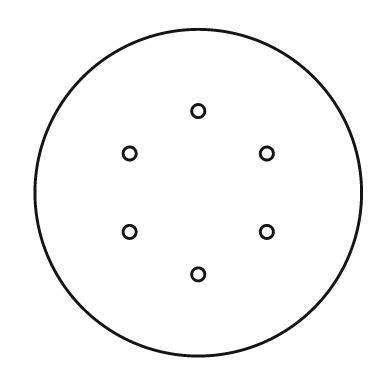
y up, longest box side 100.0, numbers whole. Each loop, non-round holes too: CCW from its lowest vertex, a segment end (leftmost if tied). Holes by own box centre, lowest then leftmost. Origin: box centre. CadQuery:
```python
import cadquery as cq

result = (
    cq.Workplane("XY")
    .moveTo(0.0, 0.0)
    .circle(50.0)
    .moveTo(0.0, -25.0)
    .circle(2.0)
    .moveTo(-21.0, -12.0)
    .circle(2.0)
    .moveTo(21.0, -12.0)
    .circle(2.0)
    .moveTo(-21.0, 12.0)
    .circle(2.0)
    .moveTo(21.0, 12.0)
    .circle(2.0)
    .moveTo(0.0, 25.0)
    .circle(2.0)
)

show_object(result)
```